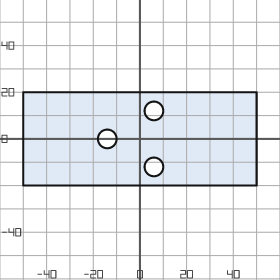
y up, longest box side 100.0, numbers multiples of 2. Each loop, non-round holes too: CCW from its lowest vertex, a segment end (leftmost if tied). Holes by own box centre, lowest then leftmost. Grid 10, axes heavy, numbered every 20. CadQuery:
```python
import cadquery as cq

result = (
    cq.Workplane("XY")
    .moveTo(-50.0, -20.0)
    .lineTo(50.0, -20.0)
    .lineTo(50.0, 20.0)
    .lineTo(-50.0, 20.0)
    .close()
    .moveTo(6.0, -12.0)
    .circle(4.0)
    .moveTo(-14.0, 0.0)
    .circle(4.0)
    .moveTo(6.0, 12.0)
    .circle(4.0)
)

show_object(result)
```